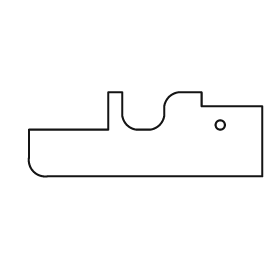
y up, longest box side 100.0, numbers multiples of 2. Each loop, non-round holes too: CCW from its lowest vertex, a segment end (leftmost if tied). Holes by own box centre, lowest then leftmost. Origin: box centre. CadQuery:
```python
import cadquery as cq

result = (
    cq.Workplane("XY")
    .moveTo(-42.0, -18.0)
    .lineTo(50.0, -18.0)
    .lineTo(50.0, 12.0)
    .lineTo(24.0, 12.0)
    .lineTo(24.0, 18.0)
    .lineTo(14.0, 18.0)
    .threePointArc((10.0, 16.0), (8.0, 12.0))
    .lineTo(8.0, 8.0)
    .threePointArc((6.0, 4.0), (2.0, 2.0))
    .lineTo(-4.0, 2.0)
    .threePointArc((-8.0, 4.0), (-10.0, 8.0))
    .lineTo(-10.0, 18.0)
    .lineTo(-16.0, 18.0)
    .lineTo(-16.0, 2.0)
    .lineTo(-50.0, 2.0)
    .lineTo(-50.0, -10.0)
    .threePointArc((-48.0, -16.0), (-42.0, -18.0))
    .close()
    .moveTo(32.0, 4.0)
    .circle(2.0)
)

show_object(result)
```